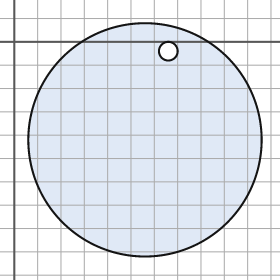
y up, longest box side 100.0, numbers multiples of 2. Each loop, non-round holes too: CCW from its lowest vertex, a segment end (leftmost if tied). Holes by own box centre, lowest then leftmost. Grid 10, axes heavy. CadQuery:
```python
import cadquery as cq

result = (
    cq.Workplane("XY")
    .moveTo(56.0, -42.0)
    .circle(50.0)
    .moveTo(66.0, -4.0)
    .circle(4.0)
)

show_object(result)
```